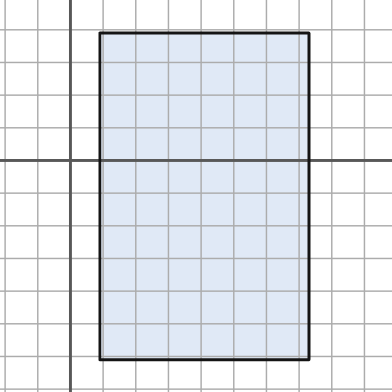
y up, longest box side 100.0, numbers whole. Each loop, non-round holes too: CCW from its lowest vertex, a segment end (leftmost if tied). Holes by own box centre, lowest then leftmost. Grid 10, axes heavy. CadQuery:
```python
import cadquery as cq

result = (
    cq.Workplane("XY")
    .moveTo(9.0, -61.0)
    .lineTo(73.0, -61.0)
    .lineTo(73.0, 39.0)
    .lineTo(9.0, 39.0)
    .close()
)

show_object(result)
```